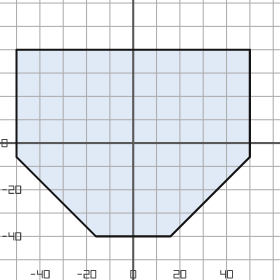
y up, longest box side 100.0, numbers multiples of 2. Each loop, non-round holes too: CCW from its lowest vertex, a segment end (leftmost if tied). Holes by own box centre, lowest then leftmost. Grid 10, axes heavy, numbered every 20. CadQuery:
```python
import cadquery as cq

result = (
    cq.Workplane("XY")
    .moveTo(-16.0, -40.0)
    .lineTo(16.0, -40.0)
    .lineTo(50.0, -6.0)
    .lineTo(50.0, 40.0)
    .lineTo(-50.0, 40.0)
    .lineTo(-50.0, -6.0)
    .close()
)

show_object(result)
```